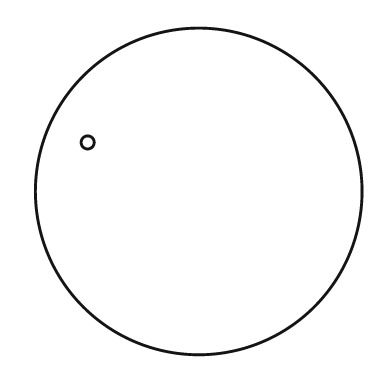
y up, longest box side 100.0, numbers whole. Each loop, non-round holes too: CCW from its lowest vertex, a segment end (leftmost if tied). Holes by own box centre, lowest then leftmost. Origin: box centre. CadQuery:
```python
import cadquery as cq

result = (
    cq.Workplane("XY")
    .moveTo(0.0, 0.0)
    .circle(50.0)
    .moveTo(-34.0, 15.0)
    .circle(2.0)
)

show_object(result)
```